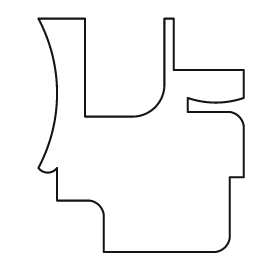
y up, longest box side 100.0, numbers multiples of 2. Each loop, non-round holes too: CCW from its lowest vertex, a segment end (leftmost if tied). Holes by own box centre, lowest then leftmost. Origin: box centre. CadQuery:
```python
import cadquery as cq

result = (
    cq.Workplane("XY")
    .moveTo(-16.0, -50.0)
    .lineTo(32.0, -50.0)
    .threePointArc((36.0, -48.0), (38.0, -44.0))
    .lineTo(38.0, -18.0)
    .lineTo(44.0, -18.0)
    .lineTo(44.0, 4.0)
    .threePointArc((42.0, 8.0), (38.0, 10.0))
    .lineTo(20.0, 10.0)
    .lineTo(20.0, 16.0)
    .threePointArc((32.0, 14.0), (44.0, 16.0))
    .lineTo(44.0, 28.0)
    .lineTo(14.0, 28.0)
    .lineTo(14.0, 50.0)
    .lineTo(10.0, 50.0)
    .lineTo(10.0, 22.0)
    .threePointArc((6.0, 12.0), (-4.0, 8.0))
    .lineTo(-24.0, 8.0)
    .lineTo(-24.0, 50.0)
    .lineTo(-44.0, 50.0)
    .threePointArc((-36.0, 18.0), (-44.0, -14.0))
    .threePointArc((-40.0, -16.0), (-36.0, -14.0))
    .lineTo(-36.0, -28.0)
    .lineTo(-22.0, -28.0)
    .threePointArc((-18.0, -30.0), (-16.0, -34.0))
    .close()
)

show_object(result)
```